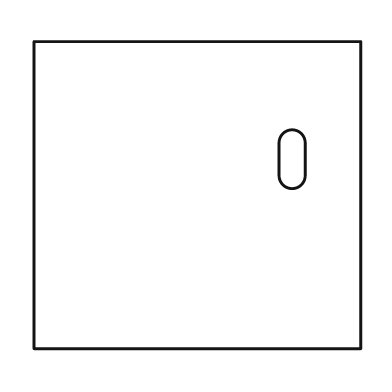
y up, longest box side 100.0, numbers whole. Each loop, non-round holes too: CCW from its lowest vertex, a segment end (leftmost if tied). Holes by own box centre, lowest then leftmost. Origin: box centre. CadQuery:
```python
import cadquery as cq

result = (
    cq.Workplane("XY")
    .moveTo(-50.0, -47.0)
    .lineTo(50.0, -47.0)
    .lineTo(50.0, 47.0)
    .lineTo(-50.0, 47.0)
    .close()
    .moveTo(25.0, 6.0)
    .threePointArc((29.0, 2.0), (33.0, 6.0))
    .lineTo(33.0, 16.0)
    .threePointArc((29.0, 20.0), (25.0, 16.0))
    .close()
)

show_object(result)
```